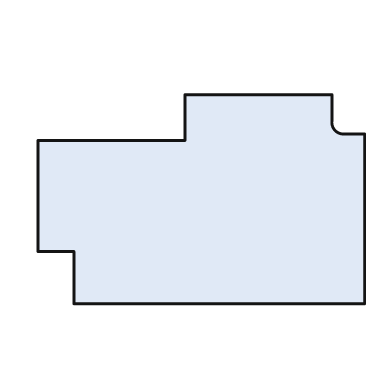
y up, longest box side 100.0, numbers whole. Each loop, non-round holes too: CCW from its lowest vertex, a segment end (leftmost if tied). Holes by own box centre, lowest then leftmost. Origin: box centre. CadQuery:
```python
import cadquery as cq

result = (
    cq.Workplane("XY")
    .moveTo(-39.0, -32.0)
    .lineTo(50.0, -32.0)
    .lineTo(50.0, 20.0)
    .lineTo(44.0, 20.0)
    .threePointArc((41.0, 21.0), (40.0, 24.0))
    .lineTo(40.0, 32.0)
    .lineTo(-5.0, 32.0)
    .lineTo(-5.0, 18.0)
    .lineTo(-50.0, 18.0)
    .lineTo(-50.0, -16.0)
    .lineTo(-39.0, -16.0)
    .close()
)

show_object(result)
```